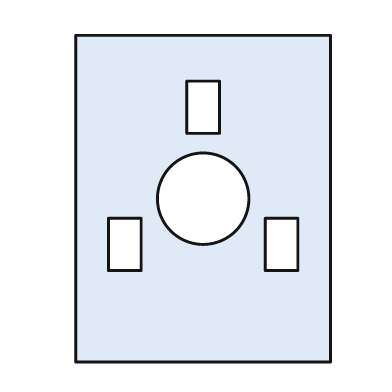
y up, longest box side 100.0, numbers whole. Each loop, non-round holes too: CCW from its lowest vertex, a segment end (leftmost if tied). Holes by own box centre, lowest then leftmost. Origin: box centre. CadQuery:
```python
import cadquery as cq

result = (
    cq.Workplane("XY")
    .moveTo(-39.0, -50.0)
    .lineTo(39.0, -50.0)
    .lineTo(39.0, 50.0)
    .lineTo(-39.0, 50.0)
    .close()
    .moveTo(-29.0, -22.0)
    .lineTo(-19.0, -22.0)
    .lineTo(-19.0, -6.0)
    .lineTo(-29.0, -6.0)
    .close()
    .moveTo(19.0, -22.0)
    .lineTo(29.0, -22.0)
    .lineTo(29.0, -6.0)
    .lineTo(19.0, -6.0)
    .close()
    .moveTo(0.0, 0.0)
    .circle(14.0)
    .moveTo(-5.0, 20.0)
    .lineTo(5.0, 20.0)
    .lineTo(5.0, 36.0)
    .lineTo(-5.0, 36.0)
    .close()
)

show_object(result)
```